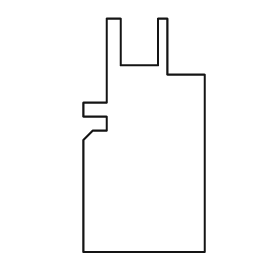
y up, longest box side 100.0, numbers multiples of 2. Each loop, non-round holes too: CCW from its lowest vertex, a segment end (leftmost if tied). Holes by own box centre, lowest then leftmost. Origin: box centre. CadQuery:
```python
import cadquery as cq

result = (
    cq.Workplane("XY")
    .moveTo(-26.0, -50.0)
    .lineTo(26.0, -50.0)
    .lineTo(26.0, 26.0)
    .lineTo(10.0, 26.0)
    .lineTo(10.0, 50.0)
    .lineTo(6.0, 50.0)
    .lineTo(6.0, 30.0)
    .lineTo(-10.0, 30.0)
    .lineTo(-10.0, 50.0)
    .lineTo(-16.0, 50.0)
    .lineTo(-16.0, 14.0)
    .lineTo(-26.0, 14.0)
    .lineTo(-26.0, 8.0)
    .lineTo(-16.0, 8.0)
    .lineTo(-16.0, 2.0)
    .lineTo(-22.0, 2.0)
    .lineTo(-26.0, -2.0)
    .close()
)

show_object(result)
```